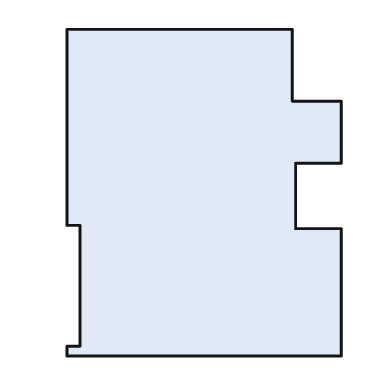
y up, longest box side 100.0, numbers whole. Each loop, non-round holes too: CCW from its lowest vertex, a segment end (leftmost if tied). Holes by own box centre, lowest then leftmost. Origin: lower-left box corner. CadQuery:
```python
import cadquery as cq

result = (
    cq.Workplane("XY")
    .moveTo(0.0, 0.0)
    .lineTo(84.0, 0.0)
    .lineTo(84.0, 39.0)
    .lineTo(70.0, 39.0)
    .lineTo(70.0, 59.0)
    .lineTo(84.0, 59.0)
    .lineTo(84.0, 78.0)
    .lineTo(69.0, 78.0)
    .lineTo(69.0, 100.0)
    .lineTo(0.0, 100.0)
    .lineTo(0.0, 40.0)
    .lineTo(4.0, 40.0)
    .lineTo(4.0, 3.0)
    .lineTo(0.0, 3.0)
    .close()
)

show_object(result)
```